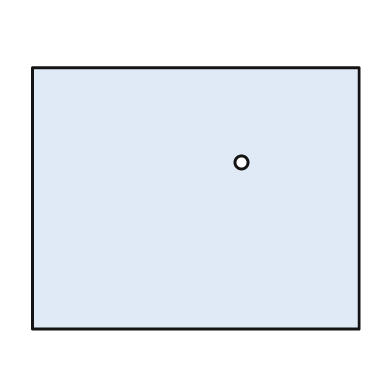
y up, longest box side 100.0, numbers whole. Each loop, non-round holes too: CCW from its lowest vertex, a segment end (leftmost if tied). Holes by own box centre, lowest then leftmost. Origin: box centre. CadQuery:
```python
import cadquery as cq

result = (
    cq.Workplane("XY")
    .moveTo(-50.0, -40.0)
    .lineTo(50.0, -40.0)
    .lineTo(50.0, 40.0)
    .lineTo(-50.0, 40.0)
    .close()
    .moveTo(14.0, 11.0)
    .circle(2.0)
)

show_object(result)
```